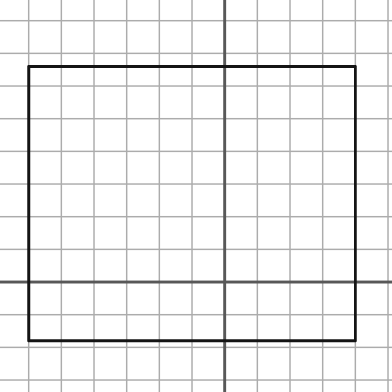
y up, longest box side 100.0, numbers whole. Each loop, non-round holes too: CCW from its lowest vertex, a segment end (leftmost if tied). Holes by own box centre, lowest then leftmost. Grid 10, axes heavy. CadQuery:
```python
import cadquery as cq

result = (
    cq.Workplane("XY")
    .moveTo(-60.0, -18.0)
    .lineTo(40.0, -18.0)
    .lineTo(40.0, 66.0)
    .lineTo(-60.0, 66.0)
    .close()
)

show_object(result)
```